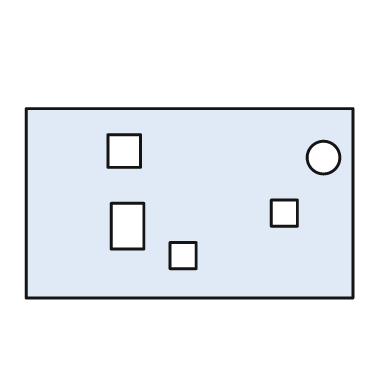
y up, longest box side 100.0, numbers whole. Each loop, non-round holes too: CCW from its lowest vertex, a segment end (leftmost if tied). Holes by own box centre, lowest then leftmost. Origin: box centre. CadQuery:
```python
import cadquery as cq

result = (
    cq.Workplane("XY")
    .moveTo(-50.0, -29.0)
    .lineTo(50.0, -29.0)
    .lineTo(50.0, 29.0)
    .lineTo(-50.0, 29.0)
    .close()
    .moveTo(-6.0, -20.0)
    .lineTo(2.0, -20.0)
    .lineTo(2.0, -12.0)
    .lineTo(-6.0, -12.0)
    .close()
    .moveTo(-24.0, -14.0)
    .lineTo(-14.0, -14.0)
    .lineTo(-14.0, 0.0)
    .lineTo(-24.0, 0.0)
    .close()
    .moveTo(25.0, -7.0)
    .lineTo(33.0, -7.0)
    .lineTo(33.0, 1.0)
    .lineTo(25.0, 1.0)
    .close()
    .moveTo(41.0, 14.0)
    .circle(5.0)
    .moveTo(-25.0, 11.0)
    .lineTo(-15.0, 11.0)
    .lineTo(-15.0, 21.0)
    .lineTo(-25.0, 21.0)
    .close()
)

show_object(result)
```